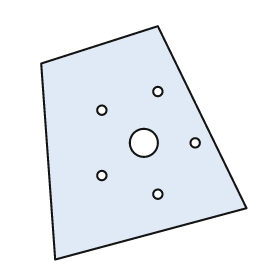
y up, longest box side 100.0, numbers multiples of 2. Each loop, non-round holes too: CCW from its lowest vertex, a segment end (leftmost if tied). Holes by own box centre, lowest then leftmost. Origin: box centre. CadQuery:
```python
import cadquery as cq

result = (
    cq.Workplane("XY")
    .moveTo(-38.0, -50.0)
    .lineTo(44.0, -28.0)
    .lineTo(6.0, 50.0)
    .lineTo(-44.0, 34.0)
    .close()
    .moveTo(6.0, -22.0)
    .circle(2.0)
    .moveTo(-18.0, -14.0)
    .circle(2.0)
    .moveTo(0.0, 0.0)
    .circle(6.0)
    .moveTo(22.0, 0.0)
    .circle(2.0)
    .moveTo(-18.0, 14.0)
    .circle(2.0)
    .moveTo(6.0, 22.0)
    .circle(2.0)
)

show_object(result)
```